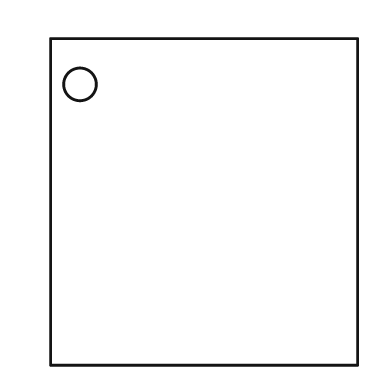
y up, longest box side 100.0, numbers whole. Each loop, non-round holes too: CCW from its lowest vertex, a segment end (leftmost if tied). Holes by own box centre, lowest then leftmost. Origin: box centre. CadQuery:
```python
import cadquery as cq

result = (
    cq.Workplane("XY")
    .moveTo(-47.0, -50.0)
    .lineTo(47.0, -50.0)
    .lineTo(47.0, 50.0)
    .lineTo(-47.0, 50.0)
    .close()
    .moveTo(-38.0, 36.0)
    .circle(5.0)
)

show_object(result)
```